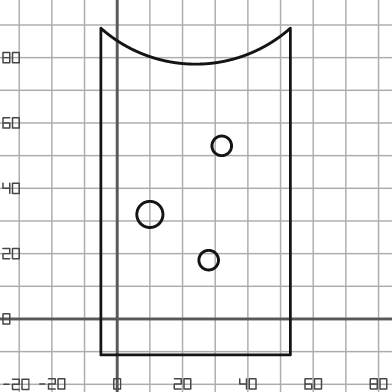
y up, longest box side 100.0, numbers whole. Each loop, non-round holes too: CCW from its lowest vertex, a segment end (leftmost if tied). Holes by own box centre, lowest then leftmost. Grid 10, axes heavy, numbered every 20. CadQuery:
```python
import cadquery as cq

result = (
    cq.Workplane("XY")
    .moveTo(-5.0, -11.0)
    .lineTo(53.0, -11.0)
    .lineTo(53.0, 89.0)
    .threePointArc((24.0, 78.0), (-5.0, 89.0))
    .close()
    .moveTo(28.0, 18.0)
    .circle(3.0)
    .moveTo(10.0, 32.0)
    .circle(4.0)
    .moveTo(32.0, 53.0)
    .circle(3.0)
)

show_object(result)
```